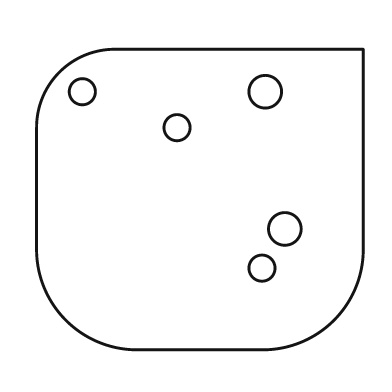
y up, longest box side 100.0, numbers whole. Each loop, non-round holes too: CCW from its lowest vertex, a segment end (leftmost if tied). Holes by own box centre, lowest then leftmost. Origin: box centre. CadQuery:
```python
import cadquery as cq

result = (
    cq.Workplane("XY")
    .moveTo(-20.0, -46.0)
    .lineTo(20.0, -46.0)
    .threePointArc((41.0, -37.0), (50.0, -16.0))
    .lineTo(50.0, 46.0)
    .lineTo(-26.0, 46.0)
    .threePointArc((-43.0, 39.0), (-50.0, 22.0))
    .lineTo(-50.0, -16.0)
    .threePointArc((-41.0, -37.0), (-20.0, -46.0))
    .close()
    .moveTo(19.0, -21.0)
    .circle(4.0)
    .moveTo(26.0, -9.0)
    .circle(5.0)
    .moveTo(-7.0, 22.0)
    .circle(4.0)
    .moveTo(-36.0, 33.0)
    .circle(4.0)
    .moveTo(20.0, 33.0)
    .circle(5.0)
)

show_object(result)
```